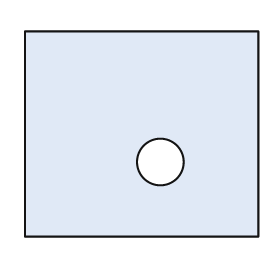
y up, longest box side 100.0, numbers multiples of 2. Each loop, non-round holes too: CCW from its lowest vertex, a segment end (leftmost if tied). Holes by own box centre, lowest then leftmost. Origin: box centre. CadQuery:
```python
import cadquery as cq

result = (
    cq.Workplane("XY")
    .moveTo(-50.0, -44.0)
    .lineTo(50.0, -44.0)
    .lineTo(50.0, 44.0)
    .lineTo(-50.0, 44.0)
    .close()
    .moveTo(8.0, -12.0)
    .circle(10.0)
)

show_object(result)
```